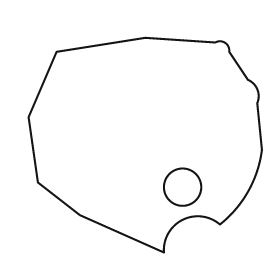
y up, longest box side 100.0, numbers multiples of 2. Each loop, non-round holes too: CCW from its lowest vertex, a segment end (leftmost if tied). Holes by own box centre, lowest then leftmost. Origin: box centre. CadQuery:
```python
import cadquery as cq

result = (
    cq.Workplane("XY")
    .moveTo(8.0, -46.0)
    .threePointArc((16.0, -32.0), (32.0, -34.0))
    .threePointArc((44.0, -20.0), (50.0, -2.0))
    .lineTo(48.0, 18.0)
    .threePointArc((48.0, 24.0), (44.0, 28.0))
    .lineTo(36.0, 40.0)
    .threePointArc((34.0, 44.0), (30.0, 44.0))
    .lineTo(0.0, 46.0)
    .lineTo(-38.0, 40.0)
    .lineTo(-50.0, 12.0)
    .lineTo(-46.0, -16.0)
    .lineTo(-28.0, -30.0)
    .close()
    .moveTo(16.0, -18.0)
    .circle(8.0)
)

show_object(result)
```